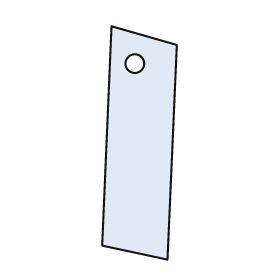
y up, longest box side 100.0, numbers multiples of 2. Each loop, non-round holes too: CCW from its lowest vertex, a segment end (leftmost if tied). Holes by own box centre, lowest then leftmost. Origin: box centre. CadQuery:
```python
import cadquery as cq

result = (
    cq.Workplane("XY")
    .moveTo(12.0, -50.0)
    .lineTo(16.0, 42.0)
    .lineTo(-12.0, 50.0)
    .lineTo(-16.0, -44.0)
    .close()
    .moveTo(-2.0, 34.0)
    .circle(4.0)
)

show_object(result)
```